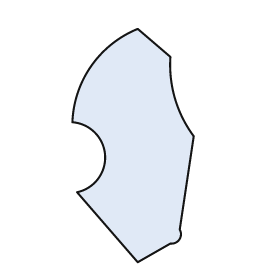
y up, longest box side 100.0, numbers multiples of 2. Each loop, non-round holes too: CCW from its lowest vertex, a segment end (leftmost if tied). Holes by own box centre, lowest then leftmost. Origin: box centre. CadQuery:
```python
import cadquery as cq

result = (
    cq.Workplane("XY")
    .moveTo(2.0, -50.0)
    .lineTo(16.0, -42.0)
    .threePointArc((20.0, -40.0), (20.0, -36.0))
    .lineTo(26.0, 4.0)
    .threePointArc((18.0, 20.0), (16.0, 38.0))
    .lineTo(2.0, 50.0)
    .threePointArc((-18.0, 34.0), (-26.0, 10.0))
    .threePointArc((-12.0, -4.0), (-24.0, -20.0))
    .close()
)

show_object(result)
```